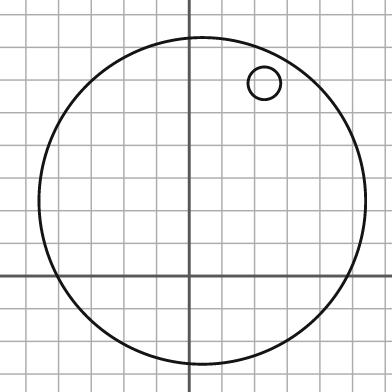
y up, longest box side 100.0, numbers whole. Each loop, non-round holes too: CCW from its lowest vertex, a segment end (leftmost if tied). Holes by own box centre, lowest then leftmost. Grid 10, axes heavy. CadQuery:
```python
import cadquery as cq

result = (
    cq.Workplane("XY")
    .moveTo(4.0, 23.0)
    .circle(50.0)
    .moveTo(23.0, 59.0)
    .circle(5.0)
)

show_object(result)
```